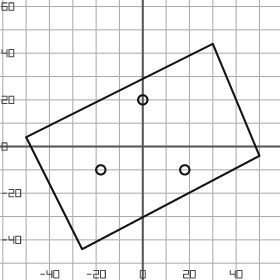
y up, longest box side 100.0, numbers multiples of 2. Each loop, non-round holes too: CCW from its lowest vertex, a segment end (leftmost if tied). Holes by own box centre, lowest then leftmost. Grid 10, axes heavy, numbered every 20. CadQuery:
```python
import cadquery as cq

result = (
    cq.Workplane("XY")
    .moveTo(-26.0, -44.0)
    .lineTo(50.0, -4.0)
    .lineTo(30.0, 44.0)
    .lineTo(-50.0, 4.0)
    .close()
    .moveTo(-18.0, -10.0)
    .circle(2.0)
    .moveTo(18.0, -10.0)
    .circle(2.0)
    .moveTo(0.0, 20.0)
    .circle(2.0)
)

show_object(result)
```